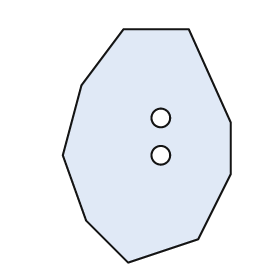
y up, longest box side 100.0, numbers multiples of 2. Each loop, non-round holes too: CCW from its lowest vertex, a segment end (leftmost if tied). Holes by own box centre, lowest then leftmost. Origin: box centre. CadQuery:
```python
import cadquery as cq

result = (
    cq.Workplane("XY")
    .moveTo(-8.0, -50.0)
    .lineTo(22.0, -40.0)
    .lineTo(36.0, -12.0)
    .lineTo(36.0, 10.0)
    .lineTo(18.0, 50.0)
    .lineTo(-10.0, 50.0)
    .lineTo(-28.0, 26.0)
    .lineTo(-36.0, -4.0)
    .lineTo(-26.0, -32.0)
    .close()
    .moveTo(6.0, -4.0)
    .circle(4.0)
    .moveTo(6.0, 12.0)
    .circle(4.0)
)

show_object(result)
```